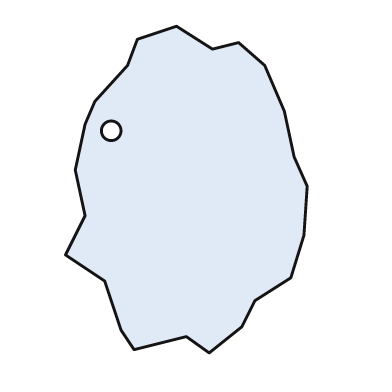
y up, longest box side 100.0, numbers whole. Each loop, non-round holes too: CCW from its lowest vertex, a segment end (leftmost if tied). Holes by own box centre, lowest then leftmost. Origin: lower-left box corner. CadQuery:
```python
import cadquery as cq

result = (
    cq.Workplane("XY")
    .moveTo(44.0, 0.0)
    .lineTo(54.0, 8.0)
    .lineTo(58.0, 16.0)
    .lineTo(69.0, 23.0)
    .lineTo(73.0, 36.0)
    .lineTo(74.0, 51.0)
    .lineTo(70.0, 60.0)
    .lineTo(67.0, 74.0)
    .lineTo(61.0, 88.0)
    .lineTo(53.0, 95.0)
    .lineTo(45.0, 93.0)
    .lineTo(34.0, 100.0)
    .lineTo(22.0, 96.0)
    .lineTo(19.0, 88.0)
    .lineTo(9.0, 77.0)
    .lineTo(6.0, 70.0)
    .lineTo(3.0, 56.0)
    .lineTo(6.0, 42.0)
    .lineTo(0.0, 30.0)
    .lineTo(12.0, 22.0)
    .lineTo(17.0, 7.0)
    .lineTo(21.0, 1.0)
    .lineTo(37.0, 5.0)
    .close()
    .moveTo(14.0, 68.0)
    .circle(3.0)
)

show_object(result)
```